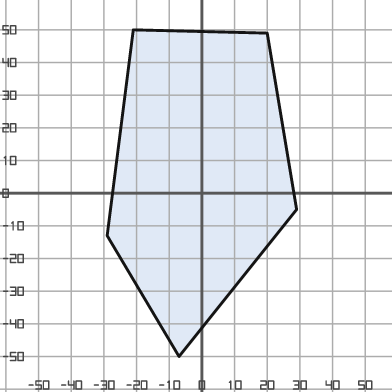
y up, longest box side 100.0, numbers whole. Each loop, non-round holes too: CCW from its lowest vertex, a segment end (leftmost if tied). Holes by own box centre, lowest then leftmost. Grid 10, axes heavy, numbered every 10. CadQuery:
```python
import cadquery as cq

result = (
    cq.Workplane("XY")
    .moveTo(-7.0, -50.0)
    .lineTo(29.0, -5.0)
    .lineTo(20.0, 49.0)
    .lineTo(-21.0, 50.0)
    .lineTo(-29.0, -13.0)
    .close()
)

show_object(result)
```